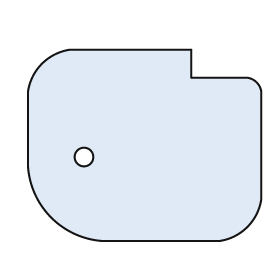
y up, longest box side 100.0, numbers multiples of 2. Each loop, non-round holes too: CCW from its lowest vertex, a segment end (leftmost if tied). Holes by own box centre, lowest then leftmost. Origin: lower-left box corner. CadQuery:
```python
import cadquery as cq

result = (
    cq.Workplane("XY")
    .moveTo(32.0, 0.0)
    .lineTo(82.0, 0.0)
    .threePointArc((94.0, 6.0), (100.0, 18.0))
    .lineTo(100.0, 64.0)
    .threePointArc((98.0, 68.0), (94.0, 70.0))
    .lineTo(70.0, 70.0)
    .lineTo(70.0, 82.0)
    .lineTo(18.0, 82.0)
    .threePointArc((6.0, 76.0), (0.0, 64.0))
    .lineTo(0.0, 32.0)
    .threePointArc((10.0, 10.0), (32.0, 0.0))
    .close()
    .moveTo(24.0, 36.0)
    .circle(4.0)
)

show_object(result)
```